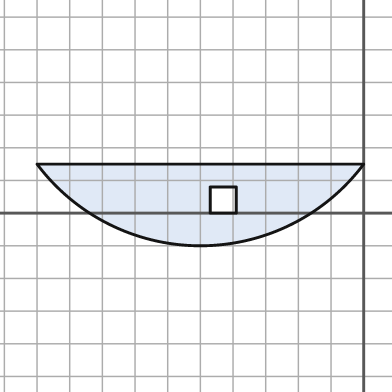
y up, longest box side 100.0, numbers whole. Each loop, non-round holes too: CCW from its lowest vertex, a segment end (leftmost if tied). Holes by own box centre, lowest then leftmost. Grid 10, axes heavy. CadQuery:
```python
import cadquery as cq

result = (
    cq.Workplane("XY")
    .moveTo(-100.0, 15.0)
    .threePointArc((-50.0, -10.0), (0.0, 15.0))
    .close()
    .moveTo(-47.0, 0.0)
    .lineTo(-39.0, 0.0)
    .lineTo(-39.0, 8.0)
    .lineTo(-47.0, 8.0)
    .close()
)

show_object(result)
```